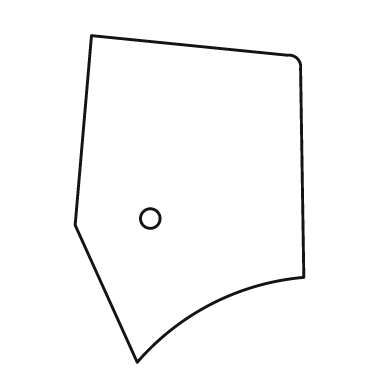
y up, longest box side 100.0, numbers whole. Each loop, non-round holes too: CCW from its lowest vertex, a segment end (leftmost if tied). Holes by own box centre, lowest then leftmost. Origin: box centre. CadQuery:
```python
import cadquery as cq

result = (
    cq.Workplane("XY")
    .moveTo(-16.0, -50.0)
    .threePointArc((7.0, -32.0), (35.0, -24.0))
    .lineTo(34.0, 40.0)
    .threePointArc((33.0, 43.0), (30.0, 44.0))
    .lineTo(-30.0, 50.0)
    .lineTo(-35.0, -8.0)
    .close()
    .moveTo(-12.0, -6.0)
    .circle(3.0)
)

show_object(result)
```